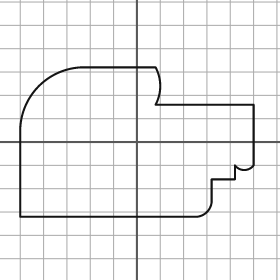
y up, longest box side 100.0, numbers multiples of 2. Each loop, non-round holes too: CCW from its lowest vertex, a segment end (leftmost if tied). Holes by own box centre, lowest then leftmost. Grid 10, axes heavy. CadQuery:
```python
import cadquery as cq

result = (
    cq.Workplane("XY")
    .moveTo(-50.0, -32.0)
    .lineTo(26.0, -32.0)
    .threePointArc((30.0, -30.0), (32.0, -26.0))
    .lineTo(32.0, -16.0)
    .lineTo(42.0, -16.0)
    .lineTo(42.0, -10.0)
    .threePointArc((46.0, -12.0), (50.0, -10.0))
    .lineTo(50.0, 16.0)
    .lineTo(8.0, 16.0)
    .threePointArc((10.0, 24.0), (8.0, 32.0))
    .lineTo(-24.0, 32.0)
    .threePointArc((-42.0, 24.0), (-50.0, 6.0))
    .close()
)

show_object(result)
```